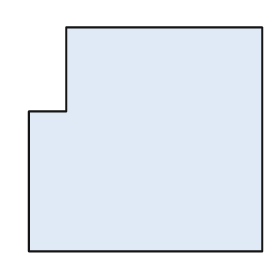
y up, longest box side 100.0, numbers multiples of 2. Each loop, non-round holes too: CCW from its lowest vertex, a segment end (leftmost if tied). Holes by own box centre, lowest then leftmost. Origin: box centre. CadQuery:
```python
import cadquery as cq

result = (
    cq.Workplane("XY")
    .moveTo(-50.0, -48.0)
    .lineTo(50.0, -48.0)
    .lineTo(50.0, 48.0)
    .lineTo(-34.0, 48.0)
    .lineTo(-34.0, 12.0)
    .lineTo(-50.0, 12.0)
    .close()
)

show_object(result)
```